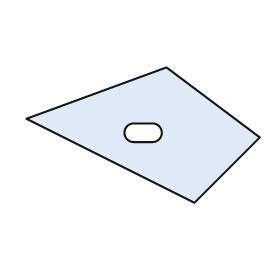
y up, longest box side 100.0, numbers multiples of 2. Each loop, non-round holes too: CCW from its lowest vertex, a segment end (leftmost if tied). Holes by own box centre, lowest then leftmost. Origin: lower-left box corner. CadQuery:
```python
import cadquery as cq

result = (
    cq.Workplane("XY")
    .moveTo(72.0, 0.0)
    .lineTo(100.0, 28.0)
    .lineTo(60.0, 58.0)
    .lineTo(0.0, 36.0)
    .close()
    .moveTo(46.0, 26.0)
    .lineTo(54.0, 26.0)
    .threePointArc((58.0, 30.0), (54.0, 34.0))
    .lineTo(46.0, 34.0)
    .threePointArc((42.0, 30.0), (46.0, 26.0))
    .close()
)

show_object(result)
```